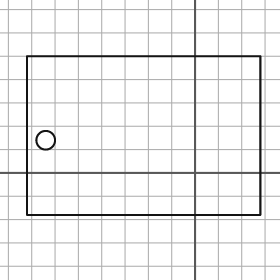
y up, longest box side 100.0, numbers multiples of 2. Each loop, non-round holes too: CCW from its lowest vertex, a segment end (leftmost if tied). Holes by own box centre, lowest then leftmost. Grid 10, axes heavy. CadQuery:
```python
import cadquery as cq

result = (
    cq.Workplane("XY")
    .moveTo(-72.0, -18.0)
    .lineTo(28.0, -18.0)
    .lineTo(28.0, 50.0)
    .lineTo(-72.0, 50.0)
    .close()
    .moveTo(-64.0, 14.0)
    .circle(4.0)
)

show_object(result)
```